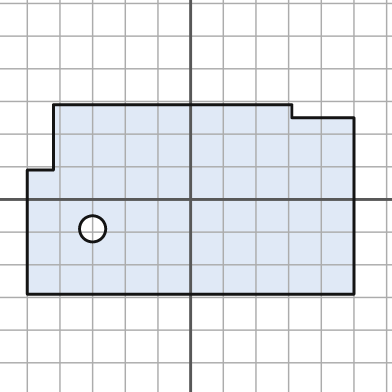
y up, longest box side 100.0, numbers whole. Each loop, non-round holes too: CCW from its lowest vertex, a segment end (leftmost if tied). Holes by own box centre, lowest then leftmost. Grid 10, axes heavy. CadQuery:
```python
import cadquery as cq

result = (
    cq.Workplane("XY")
    .moveTo(-50.0, -29.0)
    .lineTo(50.0, -29.0)
    .lineTo(50.0, 25.0)
    .lineTo(31.0, 25.0)
    .lineTo(31.0, 29.0)
    .lineTo(-42.0, 29.0)
    .lineTo(-42.0, 9.0)
    .lineTo(-50.0, 9.0)
    .close()
    .moveTo(-30.0, -9.0)
    .circle(4.0)
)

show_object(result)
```